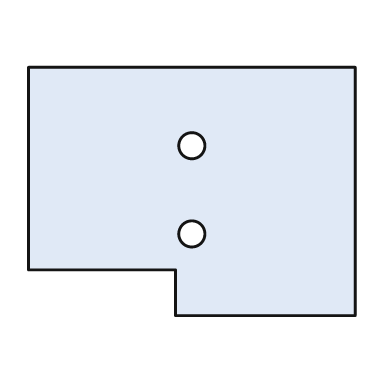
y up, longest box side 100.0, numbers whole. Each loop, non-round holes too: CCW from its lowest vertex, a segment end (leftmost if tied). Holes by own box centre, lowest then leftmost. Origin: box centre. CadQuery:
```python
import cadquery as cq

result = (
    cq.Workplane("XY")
    .moveTo(-5.0, -38.0)
    .lineTo(50.0, -38.0)
    .lineTo(50.0, 38.0)
    .lineTo(-50.0, 38.0)
    .lineTo(-50.0, -24.0)
    .lineTo(-5.0, -24.0)
    .close()
    .moveTo(0.0, -13.0)
    .circle(4.0)
    .moveTo(0.0, 14.0)
    .circle(4.0)
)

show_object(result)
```